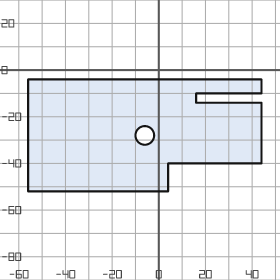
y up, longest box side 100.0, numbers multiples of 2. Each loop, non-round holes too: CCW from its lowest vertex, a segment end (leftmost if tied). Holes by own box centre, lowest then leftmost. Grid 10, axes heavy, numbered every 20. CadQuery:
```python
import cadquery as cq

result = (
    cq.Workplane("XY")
    .moveTo(-56.0, -52.0)
    .lineTo(4.0, -52.0)
    .lineTo(4.0, -40.0)
    .lineTo(44.0, -40.0)
    .lineTo(44.0, -14.0)
    .lineTo(16.0, -14.0)
    .lineTo(16.0, -10.0)
    .lineTo(44.0, -10.0)
    .lineTo(44.0, -4.0)
    .lineTo(-56.0, -4.0)
    .close()
    .moveTo(-6.0, -28.0)
    .circle(4.0)
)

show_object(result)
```